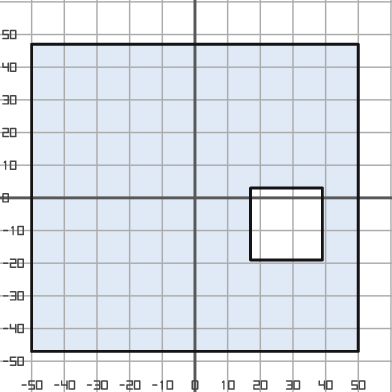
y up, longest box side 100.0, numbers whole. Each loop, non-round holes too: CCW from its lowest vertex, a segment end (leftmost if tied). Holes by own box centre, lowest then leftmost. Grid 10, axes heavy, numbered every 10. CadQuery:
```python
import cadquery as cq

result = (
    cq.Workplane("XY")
    .moveTo(-50.0, -47.0)
    .lineTo(50.0, -47.0)
    .lineTo(50.0, 47.0)
    .lineTo(-50.0, 47.0)
    .close()
    .moveTo(17.0, -19.0)
    .lineTo(39.0, -19.0)
    .lineTo(39.0, 3.0)
    .lineTo(17.0, 3.0)
    .close()
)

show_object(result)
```